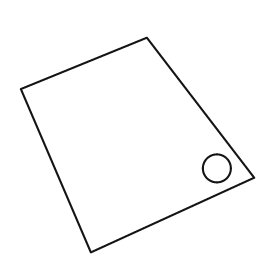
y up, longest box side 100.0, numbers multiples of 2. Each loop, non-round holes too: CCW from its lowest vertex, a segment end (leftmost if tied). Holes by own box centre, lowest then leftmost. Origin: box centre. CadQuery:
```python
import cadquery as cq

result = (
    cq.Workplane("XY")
    .moveTo(-20.0, -46.0)
    .lineTo(50.0, -14.0)
    .lineTo(4.0, 46.0)
    .lineTo(-50.0, 24.0)
    .close()
    .moveTo(34.0, -10.0)
    .circle(6.0)
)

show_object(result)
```